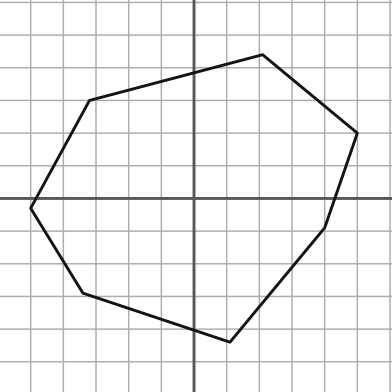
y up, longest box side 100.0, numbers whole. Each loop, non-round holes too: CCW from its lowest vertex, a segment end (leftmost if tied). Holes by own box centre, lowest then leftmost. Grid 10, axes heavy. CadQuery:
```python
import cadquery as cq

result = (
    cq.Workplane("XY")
    .moveTo(11.0, -44.0)
    .lineTo(40.0, -9.0)
    .lineTo(50.0, 20.0)
    .lineTo(21.0, 44.0)
    .lineTo(-32.0, 30.0)
    .lineTo(-50.0, -3.0)
    .lineTo(-34.0, -29.0)
    .close()
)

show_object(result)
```